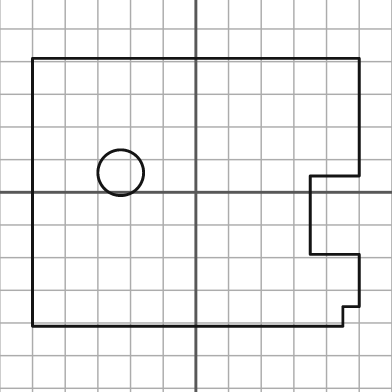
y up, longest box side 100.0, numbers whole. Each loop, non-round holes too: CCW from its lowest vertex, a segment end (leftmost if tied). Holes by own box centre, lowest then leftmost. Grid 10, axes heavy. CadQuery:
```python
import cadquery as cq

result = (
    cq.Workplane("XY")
    .moveTo(-50.0, -41.0)
    .lineTo(45.0, -41.0)
    .lineTo(45.0, -35.0)
    .lineTo(50.0, -35.0)
    .lineTo(50.0, -19.0)
    .lineTo(35.0, -19.0)
    .lineTo(35.0, 5.0)
    .lineTo(50.0, 5.0)
    .lineTo(50.0, 41.0)
    .lineTo(-50.0, 41.0)
    .close()
    .moveTo(-23.0, 6.0)
    .circle(7.0)
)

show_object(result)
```